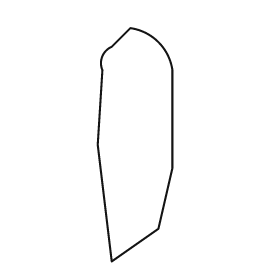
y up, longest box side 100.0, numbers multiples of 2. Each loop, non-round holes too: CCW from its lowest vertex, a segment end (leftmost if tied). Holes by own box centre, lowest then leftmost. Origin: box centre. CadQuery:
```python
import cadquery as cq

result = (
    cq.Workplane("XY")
    .moveTo(-10.0, -50.0)
    .lineTo(10.0, -36.0)
    .lineTo(16.0, -10.0)
    .lineTo(16.0, 32.0)
    .threePointArc((10.0, 44.0), (-2.0, 50.0))
    .lineTo(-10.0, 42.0)
    .threePointArc((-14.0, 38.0), (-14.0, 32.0))
    .lineTo(-16.0, 0.0)
    .close()
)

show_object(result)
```